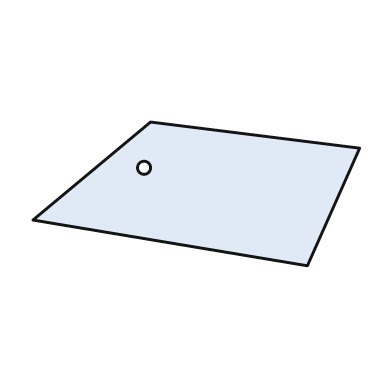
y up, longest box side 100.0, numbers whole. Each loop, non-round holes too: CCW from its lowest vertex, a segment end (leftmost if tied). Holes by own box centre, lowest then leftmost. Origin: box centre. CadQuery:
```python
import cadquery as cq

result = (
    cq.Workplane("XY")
    .moveTo(34.0, -22.0)
    .lineTo(50.0, 14.0)
    .lineTo(-14.0, 22.0)
    .lineTo(-50.0, -8.0)
    .close()
    .moveTo(-16.0, 8.0)
    .circle(2.0)
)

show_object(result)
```